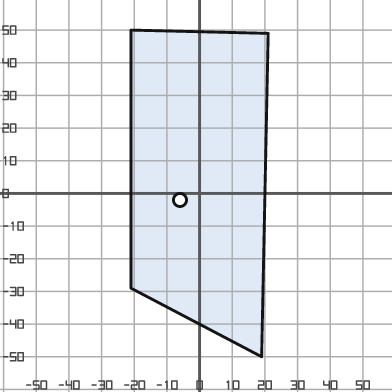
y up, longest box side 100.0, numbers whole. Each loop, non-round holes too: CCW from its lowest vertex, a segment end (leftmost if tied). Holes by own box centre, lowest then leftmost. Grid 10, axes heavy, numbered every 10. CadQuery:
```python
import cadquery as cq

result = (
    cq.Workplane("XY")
    .moveTo(19.0, -50.0)
    .lineTo(21.0, 49.0)
    .lineTo(-21.0, 50.0)
    .lineTo(-21.0, -29.0)
    .close()
    .moveTo(-6.0, -2.0)
    .circle(2.0)
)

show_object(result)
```